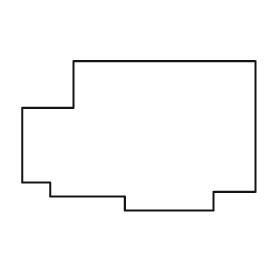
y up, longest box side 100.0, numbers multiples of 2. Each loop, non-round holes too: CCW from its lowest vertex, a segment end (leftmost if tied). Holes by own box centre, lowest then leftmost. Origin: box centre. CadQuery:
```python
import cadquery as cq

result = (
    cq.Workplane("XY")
    .moveTo(-6.0, -32.0)
    .lineTo(32.0, -32.0)
    .lineTo(32.0, -24.0)
    .lineTo(50.0, -24.0)
    .lineTo(50.0, 32.0)
    .lineTo(-28.0, 32.0)
    .lineTo(-28.0, 12.0)
    .lineTo(-50.0, 12.0)
    .lineTo(-50.0, -20.0)
    .lineTo(-38.0, -20.0)
    .lineTo(-38.0, -26.0)
    .lineTo(-6.0, -26.0)
    .close()
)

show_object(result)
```